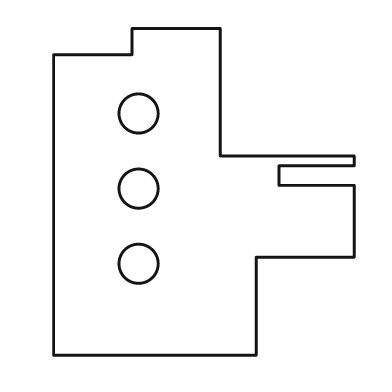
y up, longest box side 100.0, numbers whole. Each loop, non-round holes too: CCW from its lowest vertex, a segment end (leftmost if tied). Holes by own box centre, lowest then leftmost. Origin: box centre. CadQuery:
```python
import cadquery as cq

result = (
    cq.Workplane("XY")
    .moveTo(-46.0, -50.0)
    .lineTo(16.0, -50.0)
    .lineTo(16.0, -20.0)
    .lineTo(46.0, -20.0)
    .lineTo(46.0, 2.0)
    .lineTo(23.0, 2.0)
    .lineTo(23.0, 8.0)
    .lineTo(46.0, 8.0)
    .lineTo(46.0, 11.0)
    .lineTo(5.0, 11.0)
    .lineTo(5.0, 50.0)
    .lineTo(-22.0, 50.0)
    .lineTo(-22.0, 42.0)
    .lineTo(-46.0, 42.0)
    .close()
    .moveTo(-20.0, -22.0)
    .circle(6.0)
    .moveTo(-20.0, 1.0)
    .circle(6.0)
    .moveTo(-20.0, 24.0)
    .circle(6.0)
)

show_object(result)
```